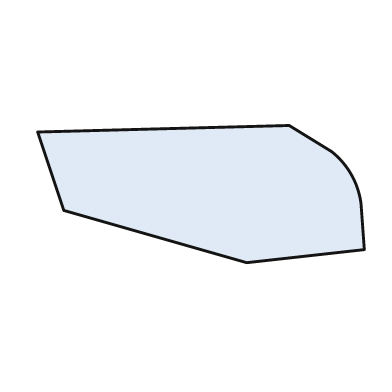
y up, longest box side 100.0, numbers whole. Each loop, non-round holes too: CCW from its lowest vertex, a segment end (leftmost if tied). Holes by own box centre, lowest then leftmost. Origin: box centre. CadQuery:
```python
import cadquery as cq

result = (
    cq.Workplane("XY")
    .moveTo(14.0, -21.0)
    .lineTo(50.0, -17.0)
    .lineTo(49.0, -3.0)
    .threePointArc((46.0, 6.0), (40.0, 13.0))
    .lineTo(27.0, 21.0)
    .lineTo(-50.0, 19.0)
    .lineTo(-42.0, -5.0)
    .close()
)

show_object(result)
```